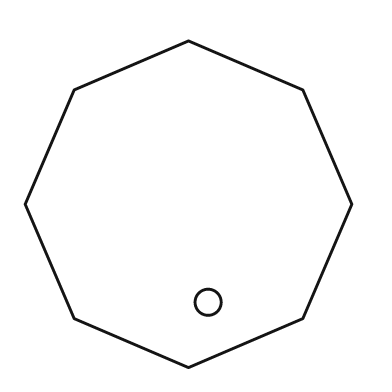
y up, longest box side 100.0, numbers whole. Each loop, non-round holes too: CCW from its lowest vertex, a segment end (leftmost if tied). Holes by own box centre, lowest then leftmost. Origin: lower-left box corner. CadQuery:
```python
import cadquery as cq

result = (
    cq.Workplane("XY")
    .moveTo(50.0, 0.0)
    .lineTo(85.0, 15.0)
    .lineTo(100.0, 50.0)
    .lineTo(85.0, 85.0)
    .lineTo(50.0, 100.0)
    .lineTo(15.0, 85.0)
    .lineTo(0.0, 50.0)
    .lineTo(15.0, 15.0)
    .close()
    .moveTo(56.0, 20.0)
    .circle(4.0)
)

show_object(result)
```